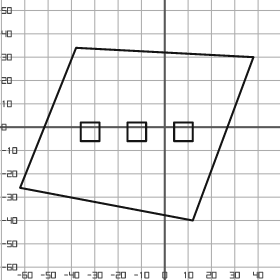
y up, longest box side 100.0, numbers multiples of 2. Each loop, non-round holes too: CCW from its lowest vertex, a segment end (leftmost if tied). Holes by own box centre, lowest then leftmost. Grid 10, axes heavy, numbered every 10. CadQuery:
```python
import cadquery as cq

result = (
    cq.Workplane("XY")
    .moveTo(12.0, -40.0)
    .lineTo(38.0, 30.0)
    .lineTo(-38.0, 34.0)
    .lineTo(-62.0, -26.0)
    .close()
    .moveTo(-36.0, -6.0)
    .lineTo(-28.0, -6.0)
    .lineTo(-28.0, 2.0)
    .lineTo(-36.0, 2.0)
    .close()
    .moveTo(-16.0, -6.0)
    .lineTo(-8.0, -6.0)
    .lineTo(-8.0, 2.0)
    .lineTo(-16.0, 2.0)
    .close()
    .moveTo(4.0, -6.0)
    .lineTo(12.0, -6.0)
    .lineTo(12.0, 2.0)
    .lineTo(4.0, 2.0)
    .close()
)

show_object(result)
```